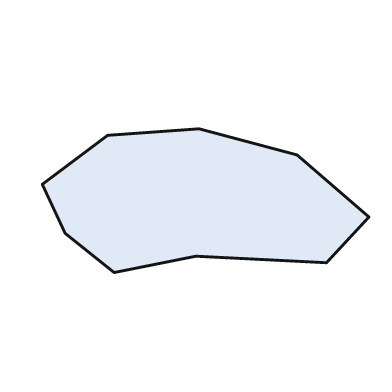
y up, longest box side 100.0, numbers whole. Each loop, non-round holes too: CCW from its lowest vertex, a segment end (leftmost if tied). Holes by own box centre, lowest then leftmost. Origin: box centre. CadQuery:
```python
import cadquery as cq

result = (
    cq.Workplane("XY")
    .moveTo(-28.0, -22.0)
    .lineTo(-3.0, -17.0)
    .lineTo(37.0, -19.0)
    .lineTo(50.0, -5.0)
    .lineTo(28.0, 14.0)
    .lineTo(-2.0, 22.0)
    .lineTo(-30.0, 20.0)
    .lineTo(-50.0, 5.0)
    .lineTo(-43.0, -10.0)
    .close()
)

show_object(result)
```